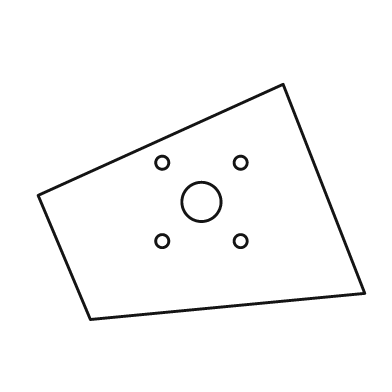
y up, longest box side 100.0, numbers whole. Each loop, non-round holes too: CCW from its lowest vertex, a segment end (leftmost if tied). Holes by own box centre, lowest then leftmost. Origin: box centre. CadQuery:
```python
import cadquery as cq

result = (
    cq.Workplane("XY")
    .moveTo(-34.0, -36.0)
    .lineTo(50.0, -28.0)
    .lineTo(25.0, 36.0)
    .lineTo(-50.0, 2.0)
    .close()
    .moveTo(-12.0, -12.0)
    .circle(2.0)
    .moveTo(12.0, -12.0)
    .circle(2.0)
    .moveTo(0.0, 0.0)
    .circle(6.0)
    .moveTo(-12.0, 12.0)
    .circle(2.0)
    .moveTo(12.0, 12.0)
    .circle(2.0)
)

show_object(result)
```